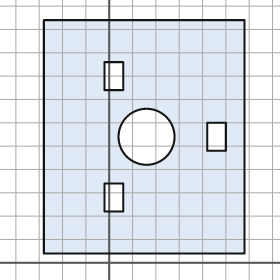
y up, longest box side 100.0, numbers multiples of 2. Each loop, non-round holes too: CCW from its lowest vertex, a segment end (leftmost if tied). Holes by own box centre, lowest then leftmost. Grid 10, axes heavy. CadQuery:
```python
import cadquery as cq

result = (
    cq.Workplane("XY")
    .moveTo(-28.0, 4.0)
    .lineTo(58.0, 4.0)
    .lineTo(58.0, 104.0)
    .lineTo(-28.0, 104.0)
    .close()
    .moveTo(-2.0, 22.0)
    .lineTo(6.0, 22.0)
    .lineTo(6.0, 34.0)
    .lineTo(-2.0, 34.0)
    .close()
    .moveTo(16.0, 54.0)
    .circle(12.0)
    .moveTo(42.0, 48.0)
    .lineTo(50.0, 48.0)
    .lineTo(50.0, 60.0)
    .lineTo(42.0, 60.0)
    .close()
    .moveTo(-2.0, 74.0)
    .lineTo(6.0, 74.0)
    .lineTo(6.0, 86.0)
    .lineTo(-2.0, 86.0)
    .close()
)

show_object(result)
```